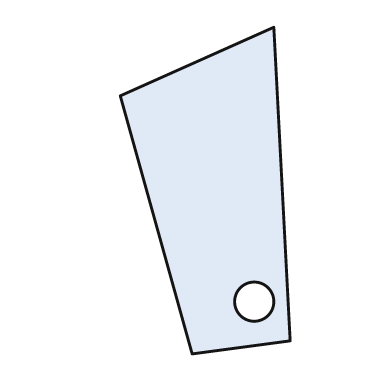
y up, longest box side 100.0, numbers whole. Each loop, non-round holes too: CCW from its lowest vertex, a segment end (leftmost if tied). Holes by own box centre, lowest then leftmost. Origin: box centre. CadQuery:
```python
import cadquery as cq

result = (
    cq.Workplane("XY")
    .moveTo(-4.0, -50.0)
    .lineTo(26.0, -46.0)
    .lineTo(21.0, 50.0)
    .lineTo(-26.0, 29.0)
    .close()
    .moveTo(15.0, -34.0)
    .circle(6.0)
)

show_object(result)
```